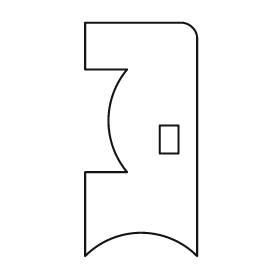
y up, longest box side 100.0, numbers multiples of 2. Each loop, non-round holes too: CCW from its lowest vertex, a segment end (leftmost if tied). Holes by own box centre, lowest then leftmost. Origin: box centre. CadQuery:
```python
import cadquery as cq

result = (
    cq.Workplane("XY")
    .moveTo(-24.0, -50.0)
    .threePointArc((0.0, -40.0), (24.0, -50.0))
    .lineTo(24.0, 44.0)
    .threePointArc((22.0, 48.0), (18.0, 50.0))
    .lineTo(-24.0, 50.0)
    .lineTo(-24.0, 30.0)
    .lineTo(-6.0, 30.0)
    .threePointArc((-14.0, 8.0), (-6.0, -14.0))
    .lineTo(-24.0, -14.0)
    .close()
    .moveTo(8.0, -6.0)
    .lineTo(16.0, -6.0)
    .lineTo(16.0, 6.0)
    .lineTo(8.0, 6.0)
    .close()
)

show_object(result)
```